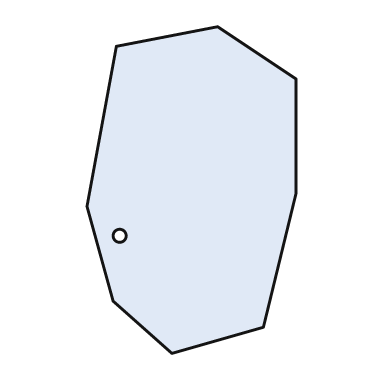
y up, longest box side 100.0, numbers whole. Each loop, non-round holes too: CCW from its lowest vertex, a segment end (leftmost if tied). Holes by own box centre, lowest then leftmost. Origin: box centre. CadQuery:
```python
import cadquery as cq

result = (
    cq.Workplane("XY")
    .moveTo(-6.0, -50.0)
    .lineTo(22.0, -42.0)
    .lineTo(32.0, -1.0)
    .lineTo(32.0, 34.0)
    .lineTo(8.0, 50.0)
    .lineTo(-23.0, 44.0)
    .lineTo(-32.0, -5.0)
    .lineTo(-24.0, -34.0)
    .close()
    .moveTo(-22.0, -14.0)
    .circle(2.0)
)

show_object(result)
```